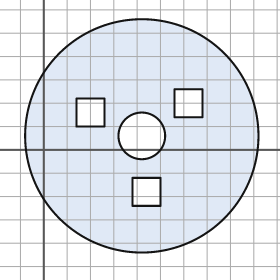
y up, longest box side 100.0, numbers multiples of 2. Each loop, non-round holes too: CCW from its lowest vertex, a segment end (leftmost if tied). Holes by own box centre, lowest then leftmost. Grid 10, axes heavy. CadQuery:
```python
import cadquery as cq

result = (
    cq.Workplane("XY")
    .moveTo(42.0, 6.0)
    .circle(50.0)
    .moveTo(38.0, -24.0)
    .lineTo(50.0, -24.0)
    .lineTo(50.0, -12.0)
    .lineTo(38.0, -12.0)
    .close()
    .moveTo(42.0, 6.0)
    .circle(10.0)
    .moveTo(14.0, 10.0)
    .lineTo(26.0, 10.0)
    .lineTo(26.0, 22.0)
    .lineTo(14.0, 22.0)
    .close()
    .moveTo(56.0, 14.0)
    .lineTo(68.0, 14.0)
    .lineTo(68.0, 26.0)
    .lineTo(56.0, 26.0)
    .close()
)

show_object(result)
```